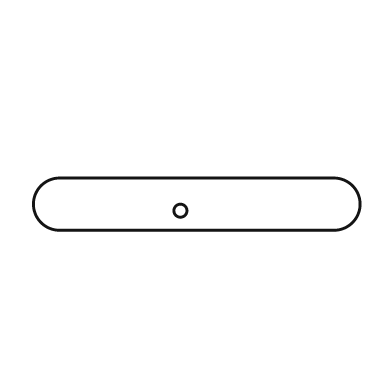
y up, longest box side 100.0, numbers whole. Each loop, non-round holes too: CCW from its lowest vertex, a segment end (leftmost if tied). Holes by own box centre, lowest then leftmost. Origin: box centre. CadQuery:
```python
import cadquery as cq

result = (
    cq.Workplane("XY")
    .moveTo(-42.0, -8.0)
    .lineTo(42.0, -8.0)
    .threePointArc((50.0, 0.0), (42.0, 8.0))
    .lineTo(-42.0, 8.0)
    .threePointArc((-50.0, 0.0), (-42.0, -8.0))
    .close()
    .moveTo(-5.0, -2.0)
    .circle(2.0)
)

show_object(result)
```